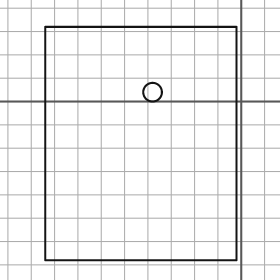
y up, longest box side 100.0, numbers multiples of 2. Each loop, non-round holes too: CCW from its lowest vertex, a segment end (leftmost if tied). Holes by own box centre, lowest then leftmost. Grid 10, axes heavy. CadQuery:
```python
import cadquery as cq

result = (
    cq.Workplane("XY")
    .moveTo(-84.0, -68.0)
    .lineTo(-2.0, -68.0)
    .lineTo(-2.0, 32.0)
    .lineTo(-84.0, 32.0)
    .close()
    .moveTo(-38.0, 4.0)
    .circle(4.0)
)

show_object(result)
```